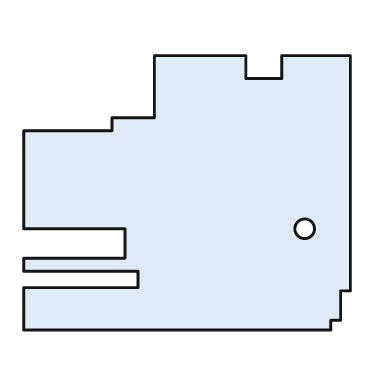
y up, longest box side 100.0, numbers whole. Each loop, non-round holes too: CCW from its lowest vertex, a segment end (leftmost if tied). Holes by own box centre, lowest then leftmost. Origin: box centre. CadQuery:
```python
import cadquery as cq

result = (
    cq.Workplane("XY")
    .moveTo(-50.0, -42.0)
    .lineTo(44.0, -42.0)
    .lineTo(44.0, -39.0)
    .lineTo(47.0, -39.0)
    .lineTo(47.0, -30.0)
    .lineTo(50.0, -30.0)
    .lineTo(50.0, 42.0)
    .lineTo(29.0, 42.0)
    .lineTo(29.0, 35.0)
    .lineTo(18.0, 35.0)
    .lineTo(18.0, 42.0)
    .lineTo(-10.0, 42.0)
    .lineTo(-10.0, 23.0)
    .lineTo(-23.0, 23.0)
    .lineTo(-23.0, 19.0)
    .lineTo(-50.0, 19.0)
    .lineTo(-50.0, -11.0)
    .lineTo(-19.0, -11.0)
    .lineTo(-19.0, -20.0)
    .lineTo(-50.0, -20.0)
    .lineTo(-50.0, -24.0)
    .lineTo(-15.0, -24.0)
    .lineTo(-15.0, -29.0)
    .lineTo(-50.0, -29.0)
    .close()
    .moveTo(36.0, -11.0)
    .circle(3.0)
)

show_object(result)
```